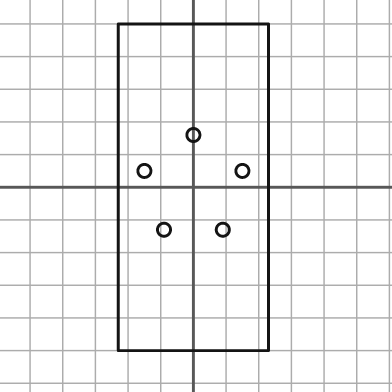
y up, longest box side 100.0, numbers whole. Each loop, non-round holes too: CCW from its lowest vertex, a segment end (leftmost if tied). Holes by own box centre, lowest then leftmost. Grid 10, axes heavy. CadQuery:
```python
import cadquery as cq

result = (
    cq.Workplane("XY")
    .moveTo(-23.0, -50.0)
    .lineTo(23.0, -50.0)
    .lineTo(23.0, 50.0)
    .lineTo(-23.0, 50.0)
    .close()
    .moveTo(-9.0, -13.0)
    .circle(2.0)
    .moveTo(9.0, -13.0)
    .circle(2.0)
    .moveTo(-15.0, 5.0)
    .circle(2.0)
    .moveTo(15.0, 5.0)
    .circle(2.0)
    .moveTo(0.0, 16.0)
    .circle(2.0)
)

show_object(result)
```